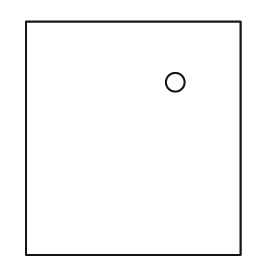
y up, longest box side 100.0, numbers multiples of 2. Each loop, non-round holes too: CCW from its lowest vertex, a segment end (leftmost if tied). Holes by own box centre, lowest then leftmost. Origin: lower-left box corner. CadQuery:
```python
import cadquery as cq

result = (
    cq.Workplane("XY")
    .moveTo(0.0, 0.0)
    .lineTo(92.0, 0.0)
    .lineTo(92.0, 100.0)
    .lineTo(0.0, 100.0)
    .close()
    .moveTo(64.0, 74.0)
    .circle(4.0)
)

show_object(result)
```